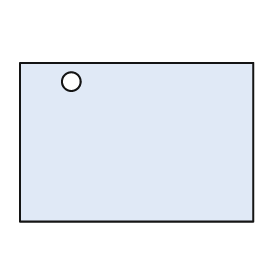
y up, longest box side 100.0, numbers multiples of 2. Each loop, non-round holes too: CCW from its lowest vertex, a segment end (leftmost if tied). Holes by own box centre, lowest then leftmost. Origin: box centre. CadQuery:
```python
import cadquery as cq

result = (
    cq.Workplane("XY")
    .moveTo(-50.0, -34.0)
    .lineTo(50.0, -34.0)
    .lineTo(50.0, 34.0)
    .lineTo(-50.0, 34.0)
    .close()
    .moveTo(-28.0, 26.0)
    .circle(4.0)
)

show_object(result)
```